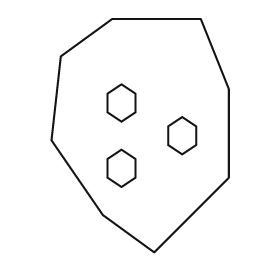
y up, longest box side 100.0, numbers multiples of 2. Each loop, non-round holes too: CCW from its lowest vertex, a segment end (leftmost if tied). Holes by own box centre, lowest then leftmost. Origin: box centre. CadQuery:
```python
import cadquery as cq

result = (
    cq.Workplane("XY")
    .moveTo(6.0, -50.0)
    .lineTo(38.0, -18.0)
    .lineTo(38.0, 20.0)
    .lineTo(26.0, 50.0)
    .lineTo(-12.0, 50.0)
    .lineTo(-34.0, 34.0)
    .lineTo(-38.0, -2.0)
    .lineTo(-16.0, -34.0)
    .close()
    .moveTo(-8.0, -22.0)
    .lineTo(-2.0, -18.0)
    .lineTo(-2.0, -10.0)
    .lineTo(-8.0, -6.0)
    .lineTo(-14.0, -10.0)
    .lineTo(-14.0, -18.0)
    .close()
    .moveTo(18.0, -8.0)
    .lineTo(24.0, -4.0)
    .lineTo(24.0, 4.0)
    .lineTo(18.0, 8.0)
    .lineTo(12.0, 4.0)
    .lineTo(12.0, -4.0)
    .close()
    .moveTo(-8.0, 6.0)
    .lineTo(-2.0, 10.0)
    .lineTo(-2.0, 18.0)
    .lineTo(-8.0, 22.0)
    .lineTo(-14.0, 18.0)
    .lineTo(-14.0, 10.0)
    .close()
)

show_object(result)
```